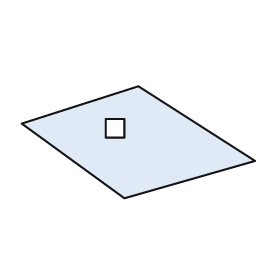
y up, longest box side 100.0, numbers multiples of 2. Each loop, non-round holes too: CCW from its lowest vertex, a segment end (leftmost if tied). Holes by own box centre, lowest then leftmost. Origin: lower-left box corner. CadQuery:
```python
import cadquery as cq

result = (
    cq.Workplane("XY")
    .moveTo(44.0, 0.0)
    .lineTo(100.0, 16.0)
    .lineTo(50.0, 48.0)
    .lineTo(0.0, 32.0)
    .close()
    .moveTo(36.0, 26.0)
    .lineTo(44.0, 26.0)
    .lineTo(44.0, 34.0)
    .lineTo(36.0, 34.0)
    .close()
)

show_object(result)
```